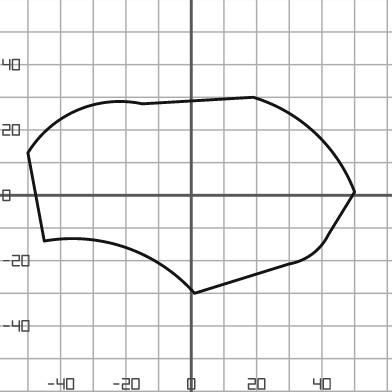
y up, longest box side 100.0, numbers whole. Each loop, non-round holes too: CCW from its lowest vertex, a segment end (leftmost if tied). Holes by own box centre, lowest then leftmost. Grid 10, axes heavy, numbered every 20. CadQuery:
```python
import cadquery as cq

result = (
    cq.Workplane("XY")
    .moveTo(1.0, -30.0)
    .lineTo(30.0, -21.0)
    .threePointArc((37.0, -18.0), (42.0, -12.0))
    .lineTo(50.0, 1.0)
    .threePointArc((38.0, 19.0), (19.0, 30.0))
    .lineTo(-15.0, 28.0)
    .threePointArc((-35.0, 26.0), (-50.0, 13.0))
    .lineTo(-45.0, -14.0)
    .threePointArc((-20.0, -16.0), (1.0, -30.0))
    .close()
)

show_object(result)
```